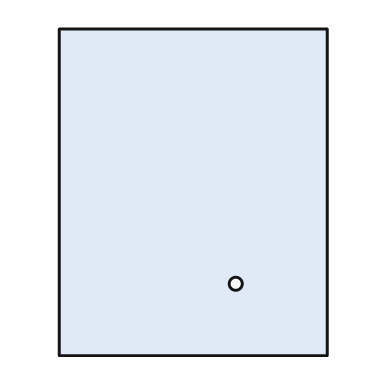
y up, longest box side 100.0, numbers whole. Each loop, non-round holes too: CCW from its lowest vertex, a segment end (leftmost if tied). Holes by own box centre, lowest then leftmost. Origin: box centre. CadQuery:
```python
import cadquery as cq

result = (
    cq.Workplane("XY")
    .moveTo(-41.0, -50.0)
    .lineTo(41.0, -50.0)
    .lineTo(41.0, 50.0)
    .lineTo(-41.0, 50.0)
    .close()
    .moveTo(13.0, -28.0)
    .circle(2.0)
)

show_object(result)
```